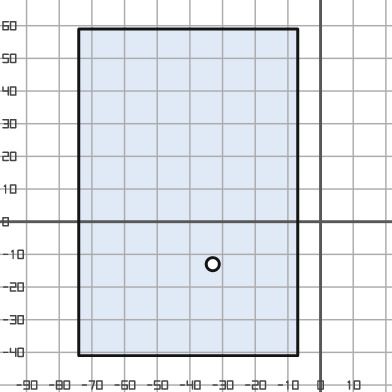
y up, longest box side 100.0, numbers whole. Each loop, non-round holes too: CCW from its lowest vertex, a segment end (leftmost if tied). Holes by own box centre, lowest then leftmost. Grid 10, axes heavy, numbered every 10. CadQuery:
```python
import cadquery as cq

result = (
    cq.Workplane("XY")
    .moveTo(-74.0, -41.0)
    .lineTo(-7.0, -41.0)
    .lineTo(-7.0, 59.0)
    .lineTo(-74.0, 59.0)
    .close()
    .moveTo(-33.0, -13.0)
    .circle(2.0)
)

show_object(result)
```